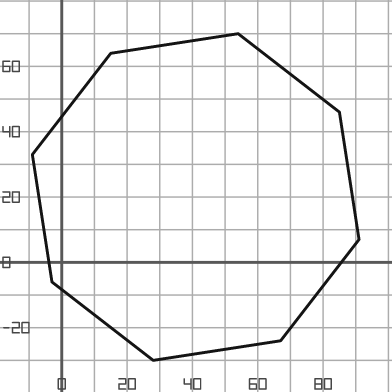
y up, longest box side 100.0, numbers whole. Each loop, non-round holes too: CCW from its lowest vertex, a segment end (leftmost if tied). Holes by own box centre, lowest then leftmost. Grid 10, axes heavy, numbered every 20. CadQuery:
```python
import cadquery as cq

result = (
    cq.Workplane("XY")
    .moveTo(28.0, -30.0)
    .lineTo(67.0, -24.0)
    .lineTo(91.0, 7.0)
    .lineTo(85.0, 46.0)
    .lineTo(54.0, 70.0)
    .lineTo(15.0, 64.0)
    .lineTo(-9.0, 33.0)
    .lineTo(-3.0, -6.0)
    .close()
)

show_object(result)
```